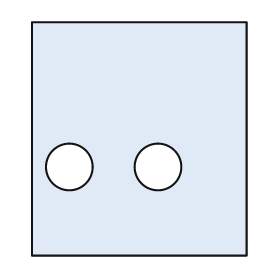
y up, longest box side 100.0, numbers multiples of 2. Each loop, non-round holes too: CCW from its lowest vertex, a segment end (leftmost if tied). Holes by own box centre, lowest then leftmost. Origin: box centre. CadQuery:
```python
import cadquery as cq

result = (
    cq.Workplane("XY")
    .moveTo(-46.0, -50.0)
    .lineTo(46.0, -50.0)
    .lineTo(46.0, 50.0)
    .lineTo(-46.0, 50.0)
    .close()
    .moveTo(-30.0, -12.0)
    .circle(10.0)
    .moveTo(8.0, -12.0)
    .circle(10.0)
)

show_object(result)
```